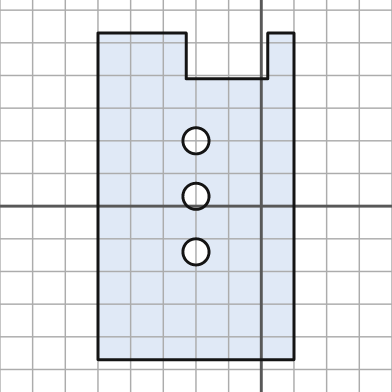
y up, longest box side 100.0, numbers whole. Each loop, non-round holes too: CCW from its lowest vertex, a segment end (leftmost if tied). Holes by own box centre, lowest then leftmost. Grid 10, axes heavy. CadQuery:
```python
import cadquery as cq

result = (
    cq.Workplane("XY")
    .moveTo(-50.0, -47.0)
    .lineTo(10.0, -47.0)
    .lineTo(10.0, 53.0)
    .lineTo(2.0, 53.0)
    .lineTo(2.0, 39.0)
    .lineTo(-23.0, 39.0)
    .lineTo(-23.0, 53.0)
    .lineTo(-50.0, 53.0)
    .close()
    .moveTo(-20.0, -14.0)
    .circle(4.0)
    .moveTo(-20.0, 3.0)
    .circle(4.0)
    .moveTo(-20.0, 20.0)
    .circle(4.0)
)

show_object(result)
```